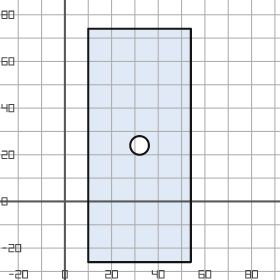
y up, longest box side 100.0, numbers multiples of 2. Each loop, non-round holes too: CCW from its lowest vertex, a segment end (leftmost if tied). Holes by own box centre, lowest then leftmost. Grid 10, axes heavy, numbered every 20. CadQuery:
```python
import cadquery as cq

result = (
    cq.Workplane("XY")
    .moveTo(10.0, -26.0)
    .lineTo(54.0, -26.0)
    .lineTo(54.0, 74.0)
    .lineTo(10.0, 74.0)
    .close()
    .moveTo(32.0, 24.0)
    .circle(4.0)
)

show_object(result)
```